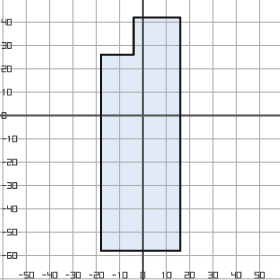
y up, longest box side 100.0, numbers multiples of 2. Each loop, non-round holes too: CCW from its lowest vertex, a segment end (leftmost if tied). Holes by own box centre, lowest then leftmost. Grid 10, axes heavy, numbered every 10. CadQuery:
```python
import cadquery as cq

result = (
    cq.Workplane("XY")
    .moveTo(-18.0, -58.0)
    .lineTo(16.0, -58.0)
    .lineTo(16.0, 42.0)
    .lineTo(-4.0, 42.0)
    .lineTo(-4.0, 26.0)
    .lineTo(-18.0, 26.0)
    .close()
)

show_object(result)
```